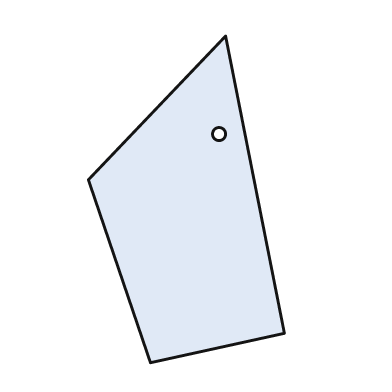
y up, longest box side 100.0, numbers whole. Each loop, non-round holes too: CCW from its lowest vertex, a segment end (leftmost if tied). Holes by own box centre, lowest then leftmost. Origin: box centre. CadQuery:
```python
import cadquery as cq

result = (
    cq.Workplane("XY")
    .moveTo(-11.0, -50.0)
    .lineTo(30.0, -41.0)
    .lineTo(12.0, 50.0)
    .lineTo(-30.0, 6.0)
    .close()
    .moveTo(10.0, 20.0)
    .circle(2.0)
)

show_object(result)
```